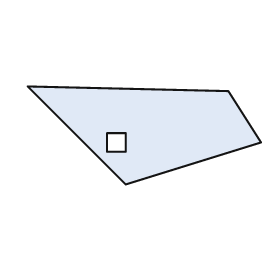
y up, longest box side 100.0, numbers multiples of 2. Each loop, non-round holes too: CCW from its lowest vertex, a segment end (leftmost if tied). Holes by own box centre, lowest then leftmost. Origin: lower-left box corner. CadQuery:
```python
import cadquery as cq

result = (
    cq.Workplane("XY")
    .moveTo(42.0, 0.0)
    .lineTo(100.0, 18.0)
    .lineTo(86.0, 40.0)
    .lineTo(0.0, 42.0)
    .close()
    .moveTo(34.0, 14.0)
    .lineTo(42.0, 14.0)
    .lineTo(42.0, 22.0)
    .lineTo(34.0, 22.0)
    .close()
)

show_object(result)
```